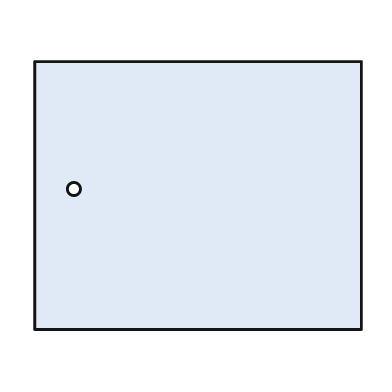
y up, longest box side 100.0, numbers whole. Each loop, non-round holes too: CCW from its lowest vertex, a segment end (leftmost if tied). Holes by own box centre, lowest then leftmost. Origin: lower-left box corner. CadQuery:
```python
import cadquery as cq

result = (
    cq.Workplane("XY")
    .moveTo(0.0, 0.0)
    .lineTo(100.0, 0.0)
    .lineTo(100.0, 82.0)
    .lineTo(0.0, 82.0)
    .close()
    .moveTo(12.0, 43.0)
    .circle(2.0)
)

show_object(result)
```